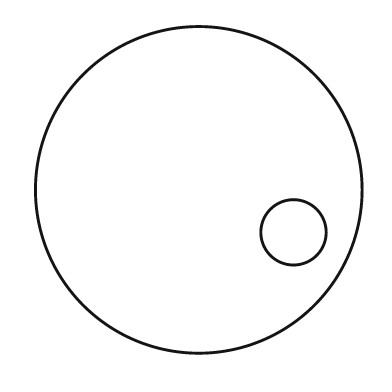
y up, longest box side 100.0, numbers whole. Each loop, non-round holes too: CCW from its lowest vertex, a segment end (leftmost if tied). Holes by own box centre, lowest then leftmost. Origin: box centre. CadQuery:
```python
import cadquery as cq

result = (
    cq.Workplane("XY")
    .moveTo(0.0, 0.0)
    .circle(50.0)
    .moveTo(29.0, -13.0)
    .circle(10.0)
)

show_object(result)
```